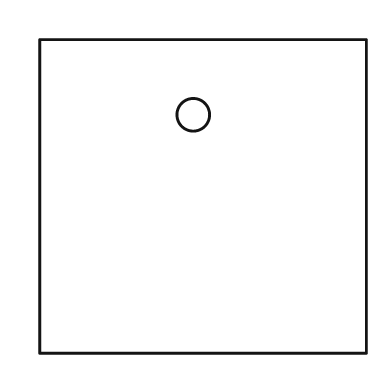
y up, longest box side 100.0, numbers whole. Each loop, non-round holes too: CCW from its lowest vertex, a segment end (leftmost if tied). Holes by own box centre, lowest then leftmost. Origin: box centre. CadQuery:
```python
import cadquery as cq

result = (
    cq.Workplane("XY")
    .moveTo(-50.0, -48.0)
    .lineTo(50.0, -48.0)
    .lineTo(50.0, 48.0)
    .lineTo(-50.0, 48.0)
    .close()
    .moveTo(-3.0, 25.0)
    .circle(5.0)
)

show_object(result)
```